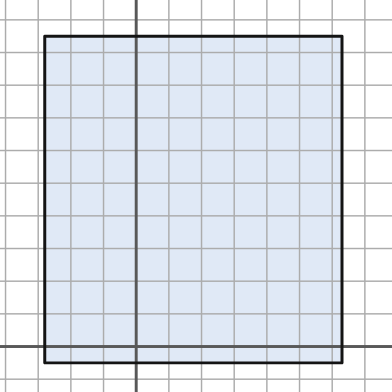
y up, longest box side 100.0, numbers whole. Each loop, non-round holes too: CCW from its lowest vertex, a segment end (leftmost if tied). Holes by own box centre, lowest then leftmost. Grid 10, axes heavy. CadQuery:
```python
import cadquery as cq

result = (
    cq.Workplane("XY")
    .moveTo(-28.0, -5.0)
    .lineTo(63.0, -5.0)
    .lineTo(63.0, 95.0)
    .lineTo(-28.0, 95.0)
    .close()
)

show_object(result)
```